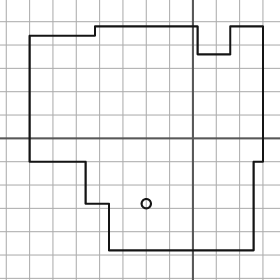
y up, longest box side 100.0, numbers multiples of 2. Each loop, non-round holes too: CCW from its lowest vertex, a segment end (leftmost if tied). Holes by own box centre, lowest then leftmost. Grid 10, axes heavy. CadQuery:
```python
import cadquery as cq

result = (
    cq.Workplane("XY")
    .moveTo(-36.0, -48.0)
    .lineTo(26.0, -48.0)
    .lineTo(26.0, -10.0)
    .lineTo(30.0, -10.0)
    .lineTo(30.0, 48.0)
    .lineTo(16.0, 48.0)
    .lineTo(16.0, 36.0)
    .lineTo(2.0, 36.0)
    .lineTo(2.0, 48.0)
    .lineTo(-42.0, 48.0)
    .lineTo(-42.0, 44.0)
    .lineTo(-70.0, 44.0)
    .lineTo(-70.0, -10.0)
    .lineTo(-46.0, -10.0)
    .lineTo(-46.0, -28.0)
    .lineTo(-36.0, -28.0)
    .close()
    .moveTo(-20.0, -28.0)
    .circle(2.0)
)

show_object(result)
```